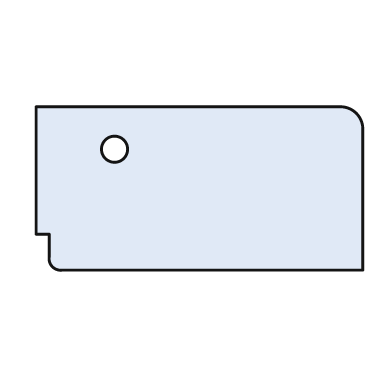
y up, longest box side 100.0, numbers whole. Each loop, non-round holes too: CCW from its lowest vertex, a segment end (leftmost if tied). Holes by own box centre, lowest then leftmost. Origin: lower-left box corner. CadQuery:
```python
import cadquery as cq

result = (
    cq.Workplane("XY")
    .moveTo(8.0, 0.0)
    .lineTo(100.0, 0.0)
    .lineTo(100.0, 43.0)
    .threePointArc((98.0, 48.0), (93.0, 50.0))
    .lineTo(0.0, 50.0)
    .lineTo(0.0, 11.0)
    .lineTo(4.0, 11.0)
    .lineTo(4.0, 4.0)
    .threePointArc((5.0, 1.0), (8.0, 0.0))
    .close()
    .moveTo(24.0, 37.0)
    .circle(4.0)
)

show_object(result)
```